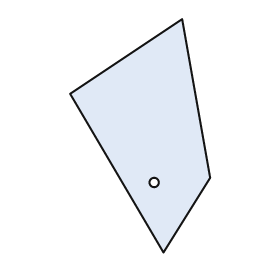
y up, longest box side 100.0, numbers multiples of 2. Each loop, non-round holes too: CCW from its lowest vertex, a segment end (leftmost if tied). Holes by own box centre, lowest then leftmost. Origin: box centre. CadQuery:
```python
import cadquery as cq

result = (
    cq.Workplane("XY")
    .moveTo(10.0, -50.0)
    .lineTo(30.0, -18.0)
    .lineTo(18.0, 50.0)
    .lineTo(-30.0, 18.0)
    .close()
    .moveTo(6.0, -20.0)
    .circle(2.0)
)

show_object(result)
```